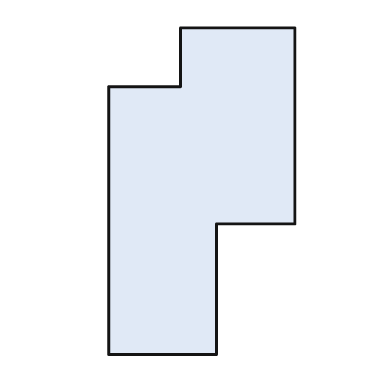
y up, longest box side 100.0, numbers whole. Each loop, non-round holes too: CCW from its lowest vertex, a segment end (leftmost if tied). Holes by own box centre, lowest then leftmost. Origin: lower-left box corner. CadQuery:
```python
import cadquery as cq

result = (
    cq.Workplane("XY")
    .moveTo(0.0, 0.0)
    .lineTo(33.0, 0.0)
    .lineTo(33.0, 40.0)
    .lineTo(57.0, 40.0)
    .lineTo(57.0, 100.0)
    .lineTo(22.0, 100.0)
    .lineTo(22.0, 82.0)
    .lineTo(0.0, 82.0)
    .close()
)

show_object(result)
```